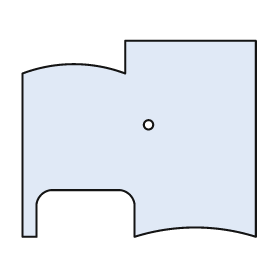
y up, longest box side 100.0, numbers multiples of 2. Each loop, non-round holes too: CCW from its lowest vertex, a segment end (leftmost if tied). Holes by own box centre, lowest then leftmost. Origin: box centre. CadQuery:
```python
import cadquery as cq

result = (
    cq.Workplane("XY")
    .moveTo(-50.0, -42.0)
    .lineTo(-44.0, -42.0)
    .lineTo(-44.0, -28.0)
    .threePointArc((-42.0, -24.0), (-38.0, -22.0))
    .lineTo(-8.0, -22.0)
    .threePointArc((-4.0, -24.0), (-2.0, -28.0))
    .lineTo(-2.0, -42.0)
    .threePointArc((24.0, -38.0), (50.0, -42.0))
    .lineTo(50.0, 42.0)
    .lineTo(-6.0, 42.0)
    .lineTo(-6.0, 28.0)
    .threePointArc((-28.0, 32.0), (-50.0, 28.0))
    .close()
    .moveTo(4.0, 6.0)
    .circle(2.0)
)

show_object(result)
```